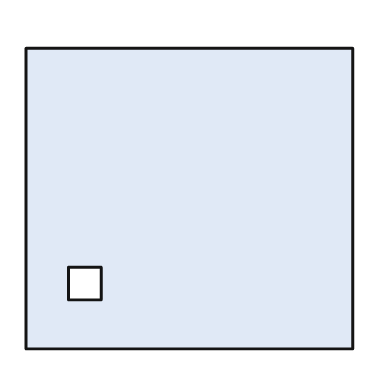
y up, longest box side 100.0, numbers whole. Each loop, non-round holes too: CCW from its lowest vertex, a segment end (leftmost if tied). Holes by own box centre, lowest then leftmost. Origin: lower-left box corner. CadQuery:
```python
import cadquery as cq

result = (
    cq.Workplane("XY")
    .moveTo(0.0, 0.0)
    .lineTo(100.0, 0.0)
    .lineTo(100.0, 92.0)
    .lineTo(0.0, 92.0)
    .close()
    .moveTo(13.0, 15.0)
    .lineTo(23.0, 15.0)
    .lineTo(23.0, 25.0)
    .lineTo(13.0, 25.0)
    .close()
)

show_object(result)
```